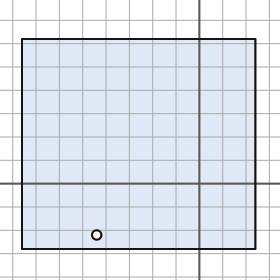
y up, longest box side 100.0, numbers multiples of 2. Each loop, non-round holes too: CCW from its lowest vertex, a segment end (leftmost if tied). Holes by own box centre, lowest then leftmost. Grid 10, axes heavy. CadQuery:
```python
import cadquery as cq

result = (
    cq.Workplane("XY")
    .moveTo(-76.0, -28.0)
    .lineTo(24.0, -28.0)
    .lineTo(24.0, 62.0)
    .lineTo(-76.0, 62.0)
    .close()
    .moveTo(-44.0, -22.0)
    .circle(2.0)
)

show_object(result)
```